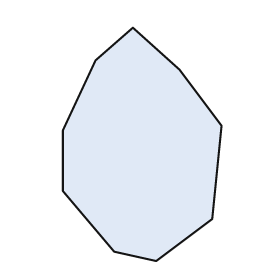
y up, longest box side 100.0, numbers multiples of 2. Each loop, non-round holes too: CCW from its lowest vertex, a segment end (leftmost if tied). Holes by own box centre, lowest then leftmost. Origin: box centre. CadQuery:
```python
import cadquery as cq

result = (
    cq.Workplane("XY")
    .moveTo(6.0, -50.0)
    .lineTo(30.0, -32.0)
    .lineTo(34.0, 8.0)
    .lineTo(16.0, 32.0)
    .lineTo(-4.0, 50.0)
    .lineTo(-20.0, 36.0)
    .lineTo(-34.0, 6.0)
    .lineTo(-34.0, -20.0)
    .lineTo(-12.0, -46.0)
    .close()
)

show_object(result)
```